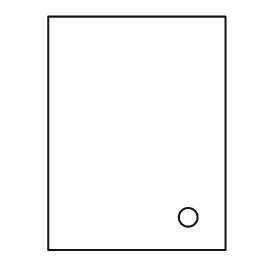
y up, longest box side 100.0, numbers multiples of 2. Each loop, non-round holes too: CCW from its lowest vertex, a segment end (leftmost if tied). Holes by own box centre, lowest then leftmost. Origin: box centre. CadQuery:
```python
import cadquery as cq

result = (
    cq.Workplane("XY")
    .moveTo(-38.0, -50.0)
    .lineTo(38.0, -50.0)
    .lineTo(38.0, 50.0)
    .lineTo(-38.0, 50.0)
    .close()
    .moveTo(22.0, -36.0)
    .circle(4.0)
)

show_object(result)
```